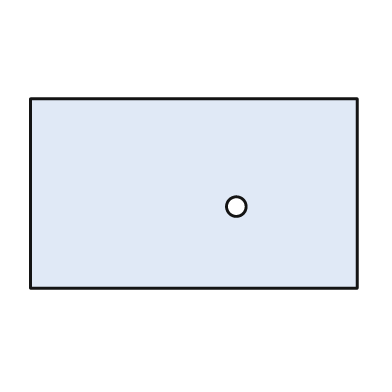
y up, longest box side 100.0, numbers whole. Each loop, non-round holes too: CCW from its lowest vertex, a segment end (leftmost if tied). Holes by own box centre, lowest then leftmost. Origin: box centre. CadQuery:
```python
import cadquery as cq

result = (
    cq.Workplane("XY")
    .moveTo(-50.0, -29.0)
    .lineTo(50.0, -29.0)
    .lineTo(50.0, 29.0)
    .lineTo(-50.0, 29.0)
    .close()
    .moveTo(13.0, -4.0)
    .circle(3.0)
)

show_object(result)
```